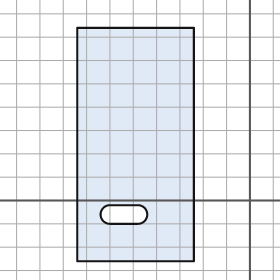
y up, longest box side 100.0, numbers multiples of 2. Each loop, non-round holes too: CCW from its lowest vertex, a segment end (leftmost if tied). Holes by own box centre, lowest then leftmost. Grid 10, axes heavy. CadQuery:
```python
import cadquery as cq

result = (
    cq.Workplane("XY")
    .moveTo(-74.0, -26.0)
    .lineTo(-24.0, -26.0)
    .lineTo(-24.0, 74.0)
    .lineTo(-74.0, 74.0)
    .close()
    .moveTo(-60.0, -10.0)
    .lineTo(-48.0, -10.0)
    .threePointArc((-44.0, -6.0), (-48.0, -2.0))
    .lineTo(-60.0, -2.0)
    .threePointArc((-64.0, -6.0), (-60.0, -10.0))
    .close()
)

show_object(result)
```